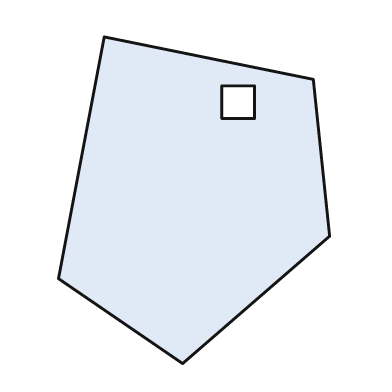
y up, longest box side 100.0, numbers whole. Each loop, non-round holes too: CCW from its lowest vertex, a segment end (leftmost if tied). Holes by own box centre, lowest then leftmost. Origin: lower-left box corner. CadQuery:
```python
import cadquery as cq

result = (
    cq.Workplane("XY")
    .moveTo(38.0, 0.0)
    .lineTo(83.0, 39.0)
    .lineTo(78.0, 87.0)
    .lineTo(14.0, 100.0)
    .lineTo(0.0, 26.0)
    .close()
    .moveTo(50.0, 75.0)
    .lineTo(60.0, 75.0)
    .lineTo(60.0, 85.0)
    .lineTo(50.0, 85.0)
    .close()
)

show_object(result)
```